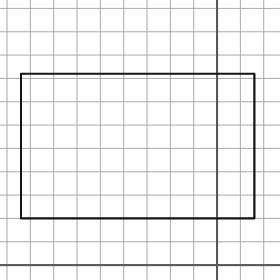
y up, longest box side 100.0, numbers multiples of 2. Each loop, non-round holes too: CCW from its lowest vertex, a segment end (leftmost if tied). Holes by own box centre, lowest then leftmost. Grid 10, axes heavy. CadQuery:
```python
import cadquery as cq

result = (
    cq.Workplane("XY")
    .moveTo(-84.0, 20.0)
    .lineTo(16.0, 20.0)
    .lineTo(16.0, 82.0)
    .lineTo(-84.0, 82.0)
    .close()
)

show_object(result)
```